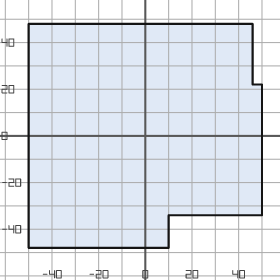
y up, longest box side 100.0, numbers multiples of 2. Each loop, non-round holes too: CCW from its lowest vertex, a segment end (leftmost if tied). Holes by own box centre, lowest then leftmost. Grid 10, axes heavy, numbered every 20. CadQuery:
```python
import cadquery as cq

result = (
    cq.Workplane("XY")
    .moveTo(-50.0, -48.0)
    .lineTo(10.0, -48.0)
    .lineTo(10.0, -34.0)
    .lineTo(50.0, -34.0)
    .lineTo(50.0, 22.0)
    .lineTo(46.0, 22.0)
    .lineTo(46.0, 48.0)
    .lineTo(-50.0, 48.0)
    .close()
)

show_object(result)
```